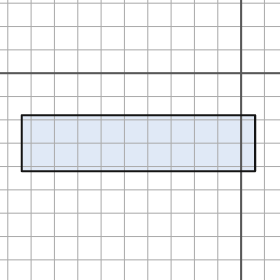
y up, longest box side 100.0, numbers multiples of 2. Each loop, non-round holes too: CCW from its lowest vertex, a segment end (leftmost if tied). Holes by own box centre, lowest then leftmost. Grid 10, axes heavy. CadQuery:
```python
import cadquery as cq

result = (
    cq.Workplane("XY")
    .moveTo(-94.0, -42.0)
    .lineTo(6.0, -42.0)
    .lineTo(6.0, -18.0)
    .lineTo(-94.0, -18.0)
    .close()
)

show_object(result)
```